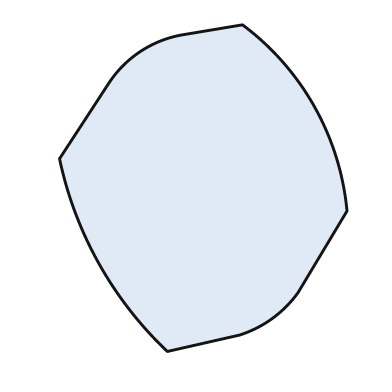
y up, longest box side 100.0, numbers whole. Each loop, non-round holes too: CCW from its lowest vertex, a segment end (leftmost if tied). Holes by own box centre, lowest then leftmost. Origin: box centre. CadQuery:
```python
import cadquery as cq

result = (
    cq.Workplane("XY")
    .moveTo(-11.0, -50.0)
    .lineTo(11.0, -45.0)
    .threePointArc((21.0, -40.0), (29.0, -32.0))
    .lineTo(44.0, -7.0)
    .threePointArc((34.0, 25.0), (12.0, 50.0))
    .lineTo(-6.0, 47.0)
    .threePointArc((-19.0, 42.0), (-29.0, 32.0))
    .lineTo(-44.0, 9.0)
    .threePointArc((-32.0, -23.0), (-11.0, -50.0))
    .close()
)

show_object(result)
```